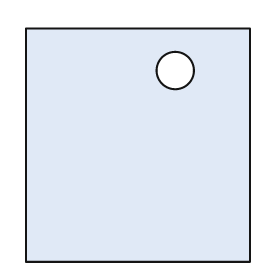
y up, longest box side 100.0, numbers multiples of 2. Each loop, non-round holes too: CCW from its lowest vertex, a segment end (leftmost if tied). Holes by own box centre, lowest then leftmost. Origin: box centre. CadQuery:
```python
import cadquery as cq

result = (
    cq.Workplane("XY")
    .moveTo(-48.0, -50.0)
    .lineTo(48.0, -50.0)
    .lineTo(48.0, 50.0)
    .lineTo(-48.0, 50.0)
    .close()
    .moveTo(16.0, 32.0)
    .circle(8.0)
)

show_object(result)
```